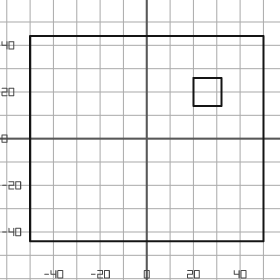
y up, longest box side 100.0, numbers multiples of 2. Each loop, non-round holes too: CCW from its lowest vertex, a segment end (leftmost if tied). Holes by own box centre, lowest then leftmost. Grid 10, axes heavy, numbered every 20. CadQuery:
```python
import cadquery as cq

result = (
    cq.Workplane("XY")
    .moveTo(-50.0, -44.0)
    .lineTo(50.0, -44.0)
    .lineTo(50.0, 44.0)
    .lineTo(-50.0, 44.0)
    .close()
    .moveTo(20.0, 14.0)
    .lineTo(32.0, 14.0)
    .lineTo(32.0, 26.0)
    .lineTo(20.0, 26.0)
    .close()
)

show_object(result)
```